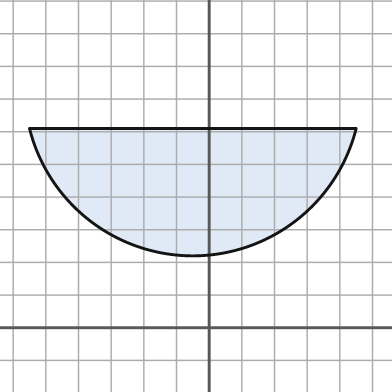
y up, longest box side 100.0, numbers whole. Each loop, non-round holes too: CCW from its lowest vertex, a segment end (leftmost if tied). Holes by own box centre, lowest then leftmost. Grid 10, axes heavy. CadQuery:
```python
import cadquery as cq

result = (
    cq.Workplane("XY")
    .moveTo(-55.0, 61.0)
    .threePointArc((-5.0, 22.0), (45.0, 61.0))
    .close()
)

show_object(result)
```